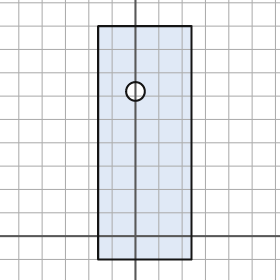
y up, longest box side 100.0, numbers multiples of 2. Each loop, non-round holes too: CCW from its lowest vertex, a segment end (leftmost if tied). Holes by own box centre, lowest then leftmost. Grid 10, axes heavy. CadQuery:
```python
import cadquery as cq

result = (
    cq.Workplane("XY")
    .moveTo(-16.0, -10.0)
    .lineTo(24.0, -10.0)
    .lineTo(24.0, 90.0)
    .lineTo(-16.0, 90.0)
    .close()
    .moveTo(0.0, 62.0)
    .circle(4.0)
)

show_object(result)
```